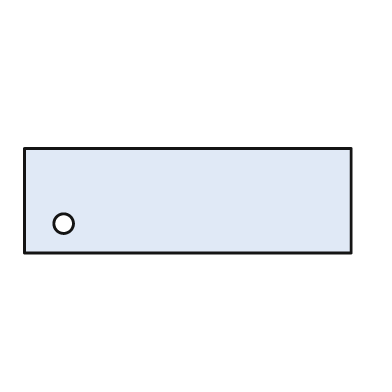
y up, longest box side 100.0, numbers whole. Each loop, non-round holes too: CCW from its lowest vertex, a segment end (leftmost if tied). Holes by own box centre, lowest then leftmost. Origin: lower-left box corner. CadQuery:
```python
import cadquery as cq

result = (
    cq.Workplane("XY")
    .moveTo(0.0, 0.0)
    .lineTo(100.0, 0.0)
    .lineTo(100.0, 32.0)
    .lineTo(0.0, 32.0)
    .close()
    .moveTo(12.0, 9.0)
    .circle(3.0)
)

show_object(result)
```